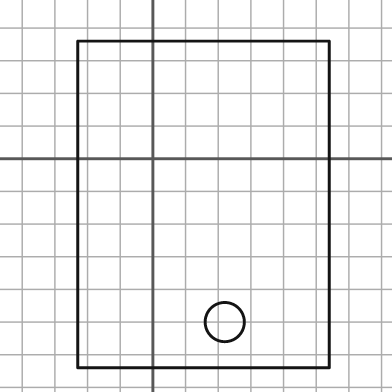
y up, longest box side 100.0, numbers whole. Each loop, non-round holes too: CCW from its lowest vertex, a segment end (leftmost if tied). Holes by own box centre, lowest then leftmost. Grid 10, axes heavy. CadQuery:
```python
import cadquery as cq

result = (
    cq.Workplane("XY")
    .moveTo(-23.0, -64.0)
    .lineTo(54.0, -64.0)
    .lineTo(54.0, 36.0)
    .lineTo(-23.0, 36.0)
    .close()
    .moveTo(22.0, -50.0)
    .circle(6.0)
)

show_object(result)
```